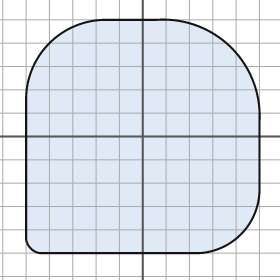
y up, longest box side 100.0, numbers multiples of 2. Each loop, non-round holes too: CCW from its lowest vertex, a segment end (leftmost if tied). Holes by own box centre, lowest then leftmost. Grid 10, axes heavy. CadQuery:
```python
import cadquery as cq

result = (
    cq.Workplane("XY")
    .moveTo(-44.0, -50.0)
    .lineTo(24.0, -50.0)
    .threePointArc((42.0, -42.0), (50.0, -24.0))
    .lineTo(50.0, 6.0)
    .threePointArc((38.0, 38.0), (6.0, 50.0))
    .lineTo(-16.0, 50.0)
    .threePointArc((-40.0, 40.0), (-50.0, 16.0))
    .lineTo(-50.0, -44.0)
    .threePointArc((-48.0, -48.0), (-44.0, -50.0))
    .close()
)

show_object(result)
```